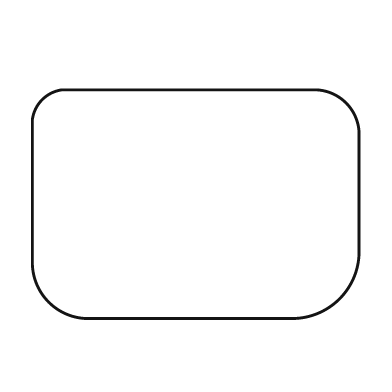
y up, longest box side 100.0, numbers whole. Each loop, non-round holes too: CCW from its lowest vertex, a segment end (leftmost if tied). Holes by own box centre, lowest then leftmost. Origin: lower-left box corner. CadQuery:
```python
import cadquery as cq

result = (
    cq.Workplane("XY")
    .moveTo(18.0, 0.0)
    .lineTo(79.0, 0.0)
    .threePointArc((94.0, 6.0), (100.0, 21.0))
    .lineTo(100.0, 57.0)
    .threePointArc((96.0, 66.0), (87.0, 70.0))
    .lineTo(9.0, 70.0)
    .threePointArc((3.0, 67.0), (0.0, 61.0))
    .lineTo(0.0, 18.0)
    .threePointArc((5.0, 5.0), (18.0, 0.0))
    .close()
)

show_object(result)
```